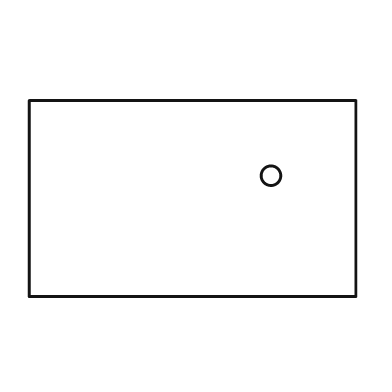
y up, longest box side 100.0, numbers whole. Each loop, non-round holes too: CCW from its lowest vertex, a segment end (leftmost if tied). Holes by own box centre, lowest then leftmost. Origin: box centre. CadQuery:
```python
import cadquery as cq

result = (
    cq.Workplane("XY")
    .moveTo(-50.0, -30.0)
    .lineTo(50.0, -30.0)
    .lineTo(50.0, 30.0)
    .lineTo(-50.0, 30.0)
    .close()
    .moveTo(24.0, 7.0)
    .circle(3.0)
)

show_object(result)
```